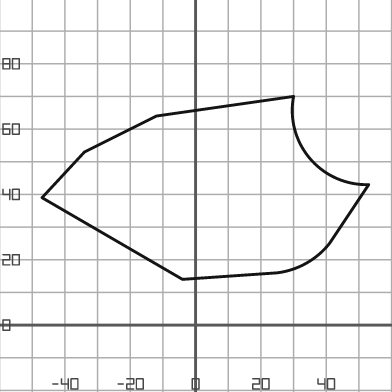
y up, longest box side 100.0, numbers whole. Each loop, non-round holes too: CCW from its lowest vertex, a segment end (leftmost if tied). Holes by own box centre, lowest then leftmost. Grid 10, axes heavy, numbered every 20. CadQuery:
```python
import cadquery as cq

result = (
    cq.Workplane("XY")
    .moveTo(-4.0, 14.0)
    .lineTo(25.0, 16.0)
    .threePointArc((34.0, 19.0), (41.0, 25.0))
    .lineTo(53.0, 43.0)
    .threePointArc((35.0, 51.0), (30.0, 70.0))
    .lineTo(-12.0, 64.0)
    .lineTo(-34.0, 53.0)
    .lineTo(-47.0, 39.0)
    .close()
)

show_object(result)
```